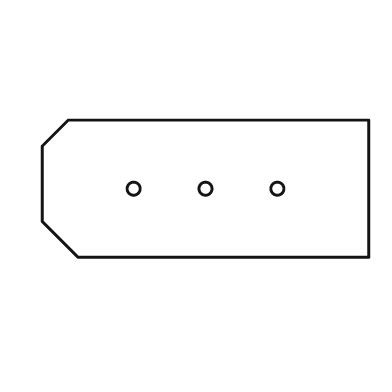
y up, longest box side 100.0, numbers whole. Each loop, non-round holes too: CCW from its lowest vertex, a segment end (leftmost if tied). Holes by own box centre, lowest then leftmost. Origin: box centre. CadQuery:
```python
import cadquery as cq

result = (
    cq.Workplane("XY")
    .moveTo(-39.0, -21.0)
    .lineTo(50.0, -21.0)
    .lineTo(50.0, 21.0)
    .lineTo(-42.0, 21.0)
    .lineTo(-50.0, 13.0)
    .lineTo(-50.0, -10.0)
    .close()
    .moveTo(-22.0, 0.0)
    .circle(2.0)
    .moveTo(0.0, 0.0)
    .circle(2.0)
    .moveTo(22.0, 0.0)
    .circle(2.0)
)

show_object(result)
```